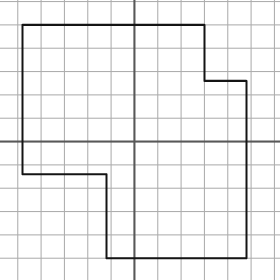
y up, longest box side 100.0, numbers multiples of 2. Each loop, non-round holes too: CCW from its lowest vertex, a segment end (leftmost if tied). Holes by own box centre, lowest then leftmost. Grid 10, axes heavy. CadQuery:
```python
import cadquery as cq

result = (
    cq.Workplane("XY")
    .moveTo(-12.0, -50.0)
    .lineTo(48.0, -50.0)
    .lineTo(48.0, 26.0)
    .lineTo(30.0, 26.0)
    .lineTo(30.0, 50.0)
    .lineTo(-48.0, 50.0)
    .lineTo(-48.0, -14.0)
    .lineTo(-12.0, -14.0)
    .close()
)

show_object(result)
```